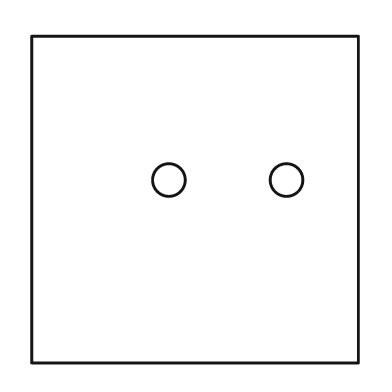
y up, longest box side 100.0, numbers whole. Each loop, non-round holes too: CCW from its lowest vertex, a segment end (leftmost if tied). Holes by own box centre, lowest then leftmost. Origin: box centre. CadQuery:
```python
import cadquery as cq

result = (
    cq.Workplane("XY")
    .moveTo(-50.0, -50.0)
    .lineTo(50.0, -50.0)
    .lineTo(50.0, 50.0)
    .lineTo(-50.0, 50.0)
    .close()
    .moveTo(-8.0, 6.0)
    .circle(5.0)
    .moveTo(28.0, 6.0)
    .circle(5.0)
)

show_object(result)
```